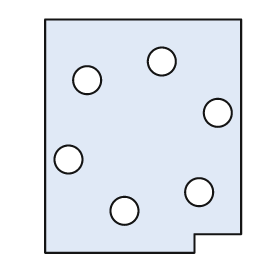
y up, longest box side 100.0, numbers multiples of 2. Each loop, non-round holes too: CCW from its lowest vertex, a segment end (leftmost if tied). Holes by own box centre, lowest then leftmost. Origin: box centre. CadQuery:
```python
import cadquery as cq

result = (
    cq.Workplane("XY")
    .moveTo(-42.0, -50.0)
    .lineTo(22.0, -50.0)
    .lineTo(22.0, -42.0)
    .lineTo(42.0, -42.0)
    .lineTo(42.0, 50.0)
    .lineTo(-42.0, 50.0)
    .close()
    .moveTo(-8.0, -32.0)
    .circle(6.0)
    .moveTo(24.0, -24.0)
    .circle(6.0)
    .moveTo(-32.0, -10.0)
    .circle(6.0)
    .moveTo(32.0, 10.0)
    .circle(6.0)
    .moveTo(-24.0, 24.0)
    .circle(6.0)
    .moveTo(8.0, 32.0)
    .circle(6.0)
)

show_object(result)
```